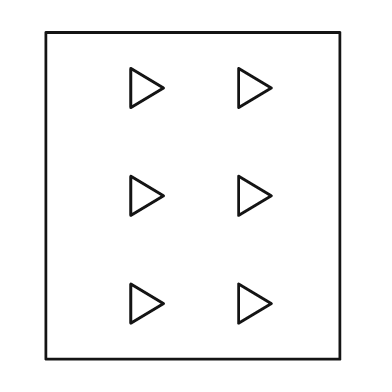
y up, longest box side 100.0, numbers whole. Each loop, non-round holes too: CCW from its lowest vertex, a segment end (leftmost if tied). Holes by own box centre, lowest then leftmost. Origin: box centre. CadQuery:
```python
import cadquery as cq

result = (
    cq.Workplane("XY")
    .moveTo(-45.0, -50.0)
    .lineTo(45.0, -50.0)
    .lineTo(45.0, 50.0)
    .lineTo(-45.0, 50.0)
    .close()
    .moveTo(-19.0, -39.0)
    .lineTo(-9.0, -33.0)
    .lineTo(-19.0, -27.0)
    .close()
    .moveTo(14.0, -39.0)
    .lineTo(24.0, -33.0)
    .lineTo(14.0, -27.0)
    .close()
    .moveTo(-19.0, -6.0)
    .lineTo(-9.0, 0.0)
    .lineTo(-19.0, 6.0)
    .close()
    .moveTo(14.0, -6.0)
    .lineTo(24.0, 0.0)
    .lineTo(14.0, 6.0)
    .close()
    .moveTo(-19.0, 27.0)
    .lineTo(-9.0, 33.0)
    .lineTo(-19.0, 39.0)
    .close()
    .moveTo(14.0, 27.0)
    .lineTo(24.0, 33.0)
    .lineTo(14.0, 39.0)
    .close()
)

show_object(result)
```